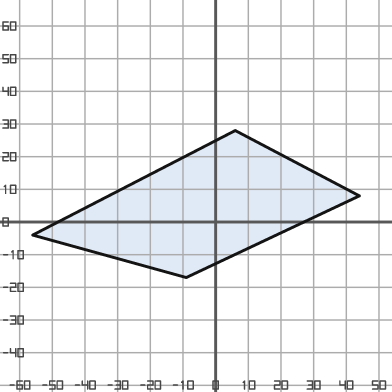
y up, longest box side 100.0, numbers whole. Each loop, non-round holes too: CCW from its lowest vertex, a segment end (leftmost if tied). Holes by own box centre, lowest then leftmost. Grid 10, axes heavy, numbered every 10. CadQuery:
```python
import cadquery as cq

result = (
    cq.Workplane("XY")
    .moveTo(-9.0, -17.0)
    .lineTo(44.0, 8.0)
    .lineTo(6.0, 28.0)
    .lineTo(-56.0, -4.0)
    .close()
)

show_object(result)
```